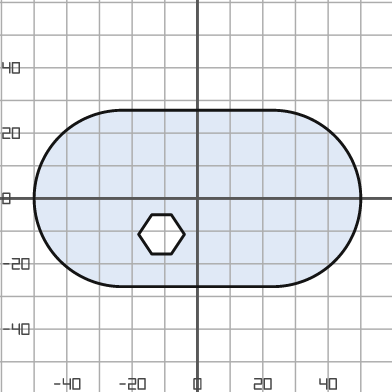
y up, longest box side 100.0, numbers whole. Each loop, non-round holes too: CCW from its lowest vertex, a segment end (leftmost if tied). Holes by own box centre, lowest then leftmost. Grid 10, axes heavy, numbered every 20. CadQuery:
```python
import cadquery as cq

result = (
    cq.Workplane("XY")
    .moveTo(-23.0, -27.0)
    .lineTo(23.0, -27.0)
    .threePointArc((50.0, 0.0), (23.0, 27.0))
    .lineTo(-23.0, 27.0)
    .threePointArc((-50.0, 0.0), (-23.0, -27.0))
    .close()
    .moveTo(-14.0, -17.0)
    .lineTo(-8.0, -17.0)
    .lineTo(-4.0, -11.0)
    .lineTo(-8.0, -5.0)
    .lineTo(-14.0, -5.0)
    .lineTo(-18.0, -11.0)
    .close()
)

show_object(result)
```